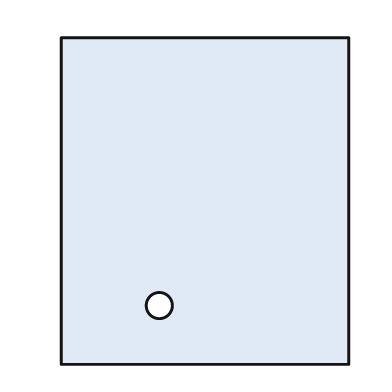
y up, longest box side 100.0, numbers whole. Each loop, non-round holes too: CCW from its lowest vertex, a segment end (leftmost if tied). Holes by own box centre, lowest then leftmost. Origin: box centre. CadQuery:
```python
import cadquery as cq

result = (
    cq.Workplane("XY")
    .moveTo(-44.0, -50.0)
    .lineTo(44.0, -50.0)
    .lineTo(44.0, 50.0)
    .lineTo(-44.0, 50.0)
    .close()
    .moveTo(-14.0, -32.0)
    .circle(4.0)
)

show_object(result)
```